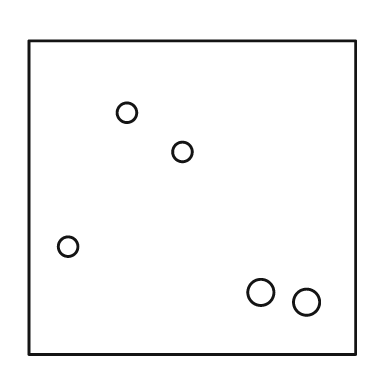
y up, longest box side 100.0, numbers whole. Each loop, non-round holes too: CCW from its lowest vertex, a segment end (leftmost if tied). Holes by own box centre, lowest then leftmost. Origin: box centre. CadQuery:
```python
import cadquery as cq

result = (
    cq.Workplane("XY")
    .moveTo(-50.0, -48.0)
    .lineTo(50.0, -48.0)
    .lineTo(50.0, 48.0)
    .lineTo(-50.0, 48.0)
    .close()
    .moveTo(35.0, -32.0)
    .circle(4.0)
    .moveTo(21.0, -29.0)
    .circle(4.0)
    .moveTo(-38.0, -15.0)
    .circle(3.0)
    .moveTo(-3.0, 14.0)
    .circle(3.0)
    .moveTo(-20.0, 26.0)
    .circle(3.0)
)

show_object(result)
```